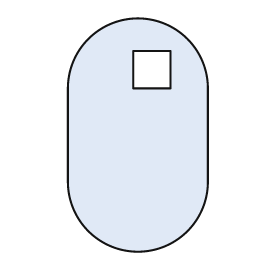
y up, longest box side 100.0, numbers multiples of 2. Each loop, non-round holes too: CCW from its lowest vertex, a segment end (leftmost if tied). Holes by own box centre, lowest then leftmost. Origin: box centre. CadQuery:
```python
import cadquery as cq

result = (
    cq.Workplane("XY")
    .moveTo(-30.0, -20.0)
    .threePointArc((0.0, -50.0), (30.0, -20.0))
    .lineTo(30.0, 20.0)
    .threePointArc((0.0, 50.0), (-30.0, 20.0))
    .close()
    .moveTo(-2.0, 20.0)
    .lineTo(14.0, 20.0)
    .lineTo(14.0, 36.0)
    .lineTo(-2.0, 36.0)
    .close()
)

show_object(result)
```